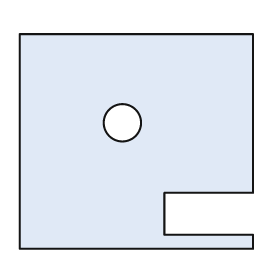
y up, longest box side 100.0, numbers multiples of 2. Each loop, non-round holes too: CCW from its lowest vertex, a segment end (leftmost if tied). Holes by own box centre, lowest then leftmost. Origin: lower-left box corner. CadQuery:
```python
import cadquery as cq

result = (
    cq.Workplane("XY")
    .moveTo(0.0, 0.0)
    .lineTo(100.0, 0.0)
    .lineTo(100.0, 6.0)
    .lineTo(62.0, 6.0)
    .lineTo(62.0, 24.0)
    .lineTo(100.0, 24.0)
    .lineTo(100.0, 92.0)
    .lineTo(0.0, 92.0)
    .close()
    .moveTo(44.0, 54.0)
    .circle(8.0)
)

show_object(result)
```